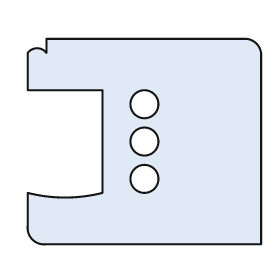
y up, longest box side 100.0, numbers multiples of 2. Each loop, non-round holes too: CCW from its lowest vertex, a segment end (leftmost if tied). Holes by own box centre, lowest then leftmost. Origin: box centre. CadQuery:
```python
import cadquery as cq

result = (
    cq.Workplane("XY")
    .moveTo(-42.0, -44.0)
    .lineTo(50.0, -44.0)
    .lineTo(50.0, 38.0)
    .threePointArc((48.0, 42.0), (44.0, 44.0))
    .lineTo(-42.0, 44.0)
    .lineTo(-42.0, 38.0)
    .threePointArc((-46.0, 40.0), (-50.0, 38.0))
    .lineTo(-50.0, 22.0)
    .lineTo(-18.0, 22.0)
    .lineTo(-18.0, -22.0)
    .threePointArc((-34.0, -24.0), (-50.0, -22.0))
    .lineTo(-50.0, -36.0)
    .threePointArc((-48.0, -42.0), (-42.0, -44.0))
    .close()
    .moveTo(0.0, -16.0)
    .circle(6.0)
    .moveTo(0.0, 0.0)
    .circle(6.0)
    .moveTo(0.0, 16.0)
    .circle(6.0)
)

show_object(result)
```